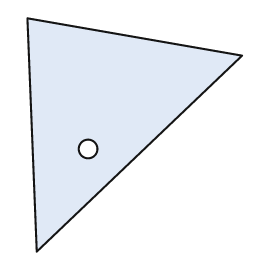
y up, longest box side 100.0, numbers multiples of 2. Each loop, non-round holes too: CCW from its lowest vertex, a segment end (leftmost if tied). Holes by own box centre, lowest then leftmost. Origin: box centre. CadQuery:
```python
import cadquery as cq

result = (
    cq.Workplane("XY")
    .moveTo(-42.0, -50.0)
    .lineTo(46.0, 34.0)
    .lineTo(-46.0, 50.0)
    .close()
    .moveTo(-20.0, -6.0)
    .circle(4.0)
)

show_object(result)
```